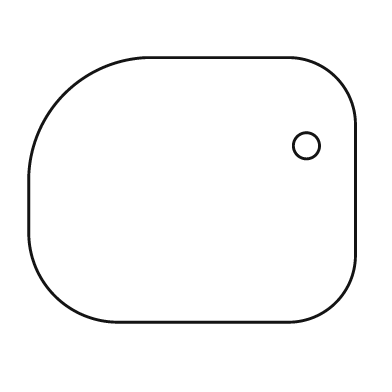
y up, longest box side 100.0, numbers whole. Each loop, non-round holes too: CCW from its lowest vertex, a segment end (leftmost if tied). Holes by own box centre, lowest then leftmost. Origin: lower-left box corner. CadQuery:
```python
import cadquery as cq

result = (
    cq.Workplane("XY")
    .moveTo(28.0, 0.0)
    .lineTo(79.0, 0.0)
    .threePointArc((94.0, 6.0), (100.0, 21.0))
    .lineTo(100.0, 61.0)
    .threePointArc((94.0, 75.0), (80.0, 81.0))
    .lineTo(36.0, 81.0)
    .threePointArc((11.0, 70.0), (0.0, 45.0))
    .lineTo(0.0, 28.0)
    .threePointArc((8.0, 8.0), (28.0, 0.0))
    .close()
    .moveTo(85.0, 54.0)
    .circle(4.0)
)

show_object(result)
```